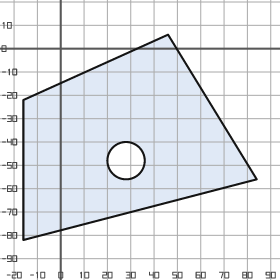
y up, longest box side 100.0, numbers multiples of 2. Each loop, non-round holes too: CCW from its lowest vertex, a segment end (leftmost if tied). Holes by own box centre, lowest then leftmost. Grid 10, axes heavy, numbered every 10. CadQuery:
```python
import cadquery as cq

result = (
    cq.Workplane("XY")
    .moveTo(-16.0, -82.0)
    .lineTo(84.0, -56.0)
    .lineTo(46.0, 6.0)
    .lineTo(-16.0, -22.0)
    .close()
    .moveTo(28.0, -48.0)
    .circle(8.0)
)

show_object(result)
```